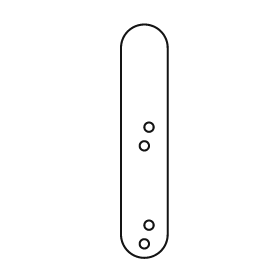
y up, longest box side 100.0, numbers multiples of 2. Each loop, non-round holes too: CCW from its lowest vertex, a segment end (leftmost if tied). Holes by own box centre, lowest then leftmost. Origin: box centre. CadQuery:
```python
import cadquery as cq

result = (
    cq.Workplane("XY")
    .moveTo(-10.0, -40.0)
    .threePointArc((0.0, -50.0), (10.0, -40.0))
    .lineTo(10.0, 40.0)
    .threePointArc((0.0, 50.0), (-10.0, 40.0))
    .close()
    .moveTo(0.0, -44.0)
    .circle(2.0)
    .moveTo(2.0, -36.0)
    .circle(2.0)
    .moveTo(0.0, -2.0)
    .circle(2.0)
    .moveTo(2.0, 6.0)
    .circle(2.0)
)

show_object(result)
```